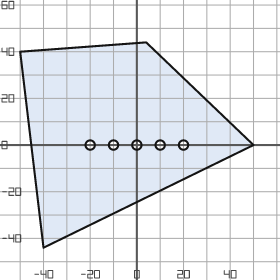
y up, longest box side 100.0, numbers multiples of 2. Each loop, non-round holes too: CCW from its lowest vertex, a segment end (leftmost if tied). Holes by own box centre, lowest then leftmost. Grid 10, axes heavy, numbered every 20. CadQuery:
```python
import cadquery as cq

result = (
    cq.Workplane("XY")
    .moveTo(-40.0, -44.0)
    .lineTo(50.0, 0.0)
    .lineTo(4.0, 44.0)
    .lineTo(-50.0, 40.0)
    .close()
    .moveTo(-20.0, 0.0)
    .circle(2.0)
    .moveTo(-10.0, 0.0)
    .circle(2.0)
    .moveTo(0.0, 0.0)
    .circle(2.0)
    .moveTo(10.0, 0.0)
    .circle(2.0)
    .moveTo(20.0, 0.0)
    .circle(2.0)
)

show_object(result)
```